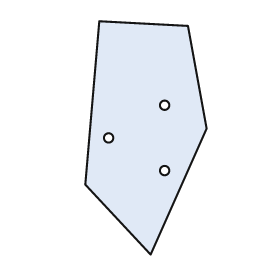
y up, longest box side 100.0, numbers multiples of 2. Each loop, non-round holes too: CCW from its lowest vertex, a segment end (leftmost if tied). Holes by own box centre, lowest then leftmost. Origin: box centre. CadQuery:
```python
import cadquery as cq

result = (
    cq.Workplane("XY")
    .moveTo(2.0, -50.0)
    .lineTo(26.0, 4.0)
    .lineTo(18.0, 48.0)
    .lineTo(-20.0, 50.0)
    .lineTo(-26.0, -20.0)
    .close()
    .moveTo(8.0, -14.0)
    .circle(2.0)
    .moveTo(-16.0, 0.0)
    .circle(2.0)
    .moveTo(8.0, 14.0)
    .circle(2.0)
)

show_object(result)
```